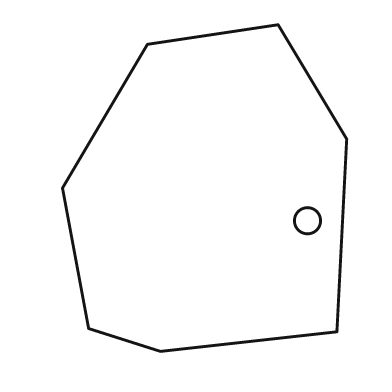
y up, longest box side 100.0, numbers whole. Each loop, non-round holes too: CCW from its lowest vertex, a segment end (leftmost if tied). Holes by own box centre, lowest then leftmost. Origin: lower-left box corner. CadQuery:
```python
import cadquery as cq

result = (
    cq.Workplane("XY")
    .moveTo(30.0, 0.0)
    .lineTo(84.0, 6.0)
    .lineTo(87.0, 65.0)
    .lineTo(66.0, 100.0)
    .lineTo(26.0, 94.0)
    .lineTo(0.0, 50.0)
    .lineTo(8.0, 7.0)
    .close()
    .moveTo(75.0, 40.0)
    .circle(4.0)
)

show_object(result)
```